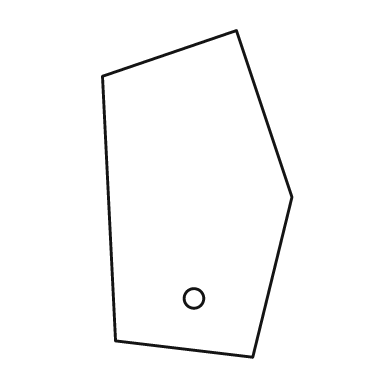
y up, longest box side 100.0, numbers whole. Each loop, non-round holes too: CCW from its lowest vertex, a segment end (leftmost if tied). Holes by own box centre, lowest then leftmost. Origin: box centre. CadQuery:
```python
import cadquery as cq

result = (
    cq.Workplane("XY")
    .moveTo(17.0, -50.0)
    .lineTo(29.0, -1.0)
    .lineTo(12.0, 50.0)
    .lineTo(-29.0, 36.0)
    .lineTo(-25.0, -45.0)
    .close()
    .moveTo(-1.0, -32.0)
    .circle(3.0)
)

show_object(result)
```